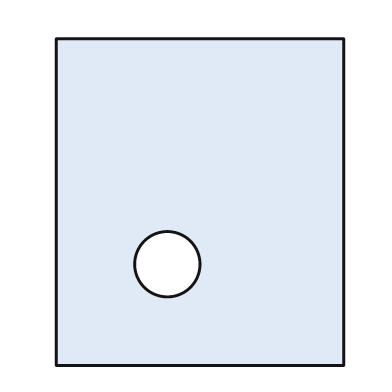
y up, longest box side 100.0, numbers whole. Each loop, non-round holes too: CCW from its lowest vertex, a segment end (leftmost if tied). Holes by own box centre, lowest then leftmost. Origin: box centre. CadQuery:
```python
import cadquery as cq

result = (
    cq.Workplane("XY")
    .moveTo(-44.0, -50.0)
    .lineTo(44.0, -50.0)
    .lineTo(44.0, 50.0)
    .lineTo(-44.0, 50.0)
    .close()
    .moveTo(-10.0, -19.0)
    .circle(10.0)
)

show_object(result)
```